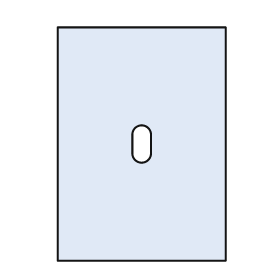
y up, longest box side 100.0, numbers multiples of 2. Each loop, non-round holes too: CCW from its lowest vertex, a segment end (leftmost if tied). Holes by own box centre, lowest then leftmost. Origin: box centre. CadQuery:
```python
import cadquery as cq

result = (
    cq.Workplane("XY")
    .moveTo(-36.0, -50.0)
    .lineTo(36.0, -50.0)
    .lineTo(36.0, 50.0)
    .lineTo(-36.0, 50.0)
    .close()
    .moveTo(-4.0, -4.0)
    .threePointArc((0.0, -8.0), (4.0, -4.0))
    .lineTo(4.0, 4.0)
    .threePointArc((0.0, 8.0), (-4.0, 4.0))
    .close()
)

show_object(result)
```